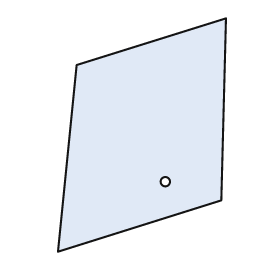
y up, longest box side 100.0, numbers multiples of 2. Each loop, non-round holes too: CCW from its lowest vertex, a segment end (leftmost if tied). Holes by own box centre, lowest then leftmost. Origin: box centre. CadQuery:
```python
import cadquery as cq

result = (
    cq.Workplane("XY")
    .moveTo(-36.0, -50.0)
    .lineTo(34.0, -28.0)
    .lineTo(36.0, 50.0)
    .lineTo(-28.0, 30.0)
    .close()
    .moveTo(10.0, -20.0)
    .circle(2.0)
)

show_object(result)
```